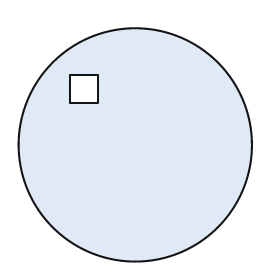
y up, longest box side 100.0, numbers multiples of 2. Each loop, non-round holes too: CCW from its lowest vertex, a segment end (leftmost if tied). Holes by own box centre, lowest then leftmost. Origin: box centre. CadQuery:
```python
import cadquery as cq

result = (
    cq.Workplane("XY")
    .moveTo(0.0, 0.0)
    .circle(50.0)
    .moveTo(-28.0, 18.0)
    .lineTo(-16.0, 18.0)
    .lineTo(-16.0, 30.0)
    .lineTo(-28.0, 30.0)
    .close()
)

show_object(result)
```